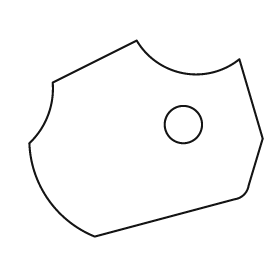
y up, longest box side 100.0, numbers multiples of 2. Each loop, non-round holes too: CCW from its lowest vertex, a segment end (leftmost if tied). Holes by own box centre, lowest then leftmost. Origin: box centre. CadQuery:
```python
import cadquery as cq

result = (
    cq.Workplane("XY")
    .moveTo(-22.0, -42.0)
    .lineTo(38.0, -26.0)
    .threePointArc((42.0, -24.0), (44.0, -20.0))
    .lineTo(50.0, 0.0)
    .lineTo(40.0, 34.0)
    .threePointArc((16.0, 28.0), (-4.0, 42.0))
    .lineTo(-40.0, 24.0)
    .threePointArc((-42.0, 10.0), (-50.0, -2.0))
    .threePointArc((-42.0, -26.0), (-22.0, -42.0))
    .close()
    .moveTo(16.0, 6.0)
    .circle(8.0)
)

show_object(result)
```